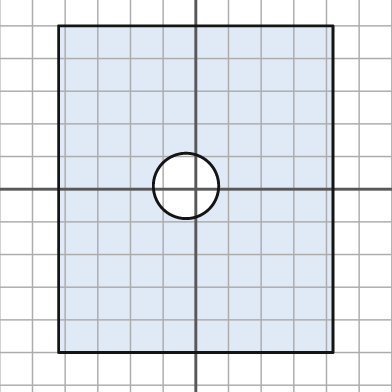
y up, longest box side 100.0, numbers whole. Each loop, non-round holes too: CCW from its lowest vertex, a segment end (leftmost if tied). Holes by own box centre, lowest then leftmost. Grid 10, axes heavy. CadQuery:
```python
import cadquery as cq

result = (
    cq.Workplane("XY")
    .moveTo(-42.0, -50.0)
    .lineTo(42.0, -50.0)
    .lineTo(42.0, 50.0)
    .lineTo(-42.0, 50.0)
    .close()
    .moveTo(-3.0, 1.0)
    .circle(10.0)
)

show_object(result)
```